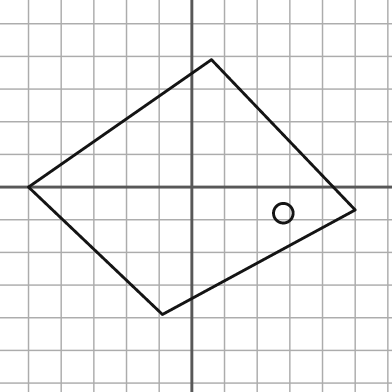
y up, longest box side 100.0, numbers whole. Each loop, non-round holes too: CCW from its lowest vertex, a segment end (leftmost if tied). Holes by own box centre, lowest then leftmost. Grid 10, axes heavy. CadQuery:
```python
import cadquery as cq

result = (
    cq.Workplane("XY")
    .moveTo(-9.0, -39.0)
    .lineTo(50.0, -7.0)
    .lineTo(6.0, 39.0)
    .lineTo(-50.0, 0.0)
    .close()
    .moveTo(28.0, -8.0)
    .circle(3.0)
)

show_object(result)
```